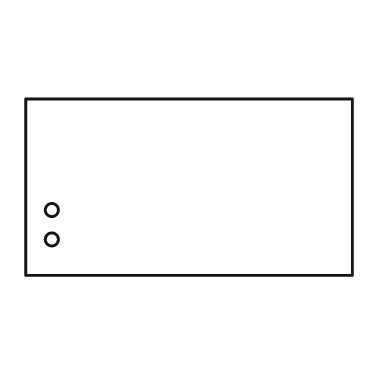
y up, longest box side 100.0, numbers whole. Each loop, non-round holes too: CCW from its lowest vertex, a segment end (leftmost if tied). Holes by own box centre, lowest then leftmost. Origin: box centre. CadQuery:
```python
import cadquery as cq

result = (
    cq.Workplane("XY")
    .moveTo(-50.0, -27.0)
    .lineTo(50.0, -27.0)
    .lineTo(50.0, 27.0)
    .lineTo(-50.0, 27.0)
    .close()
    .moveTo(-42.0, -16.0)
    .circle(2.0)
    .moveTo(-42.0, -7.0)
    .circle(2.0)
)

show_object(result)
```